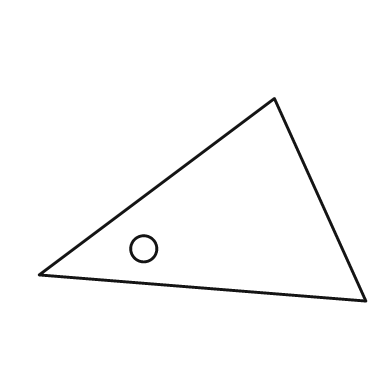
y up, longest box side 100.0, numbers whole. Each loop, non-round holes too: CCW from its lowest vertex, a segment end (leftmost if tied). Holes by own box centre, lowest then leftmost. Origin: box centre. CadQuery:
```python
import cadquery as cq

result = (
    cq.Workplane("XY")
    .moveTo(50.0, -31.0)
    .lineTo(22.0, 31.0)
    .lineTo(-50.0, -23.0)
    .close()
    .moveTo(-18.0, -15.0)
    .circle(4.0)
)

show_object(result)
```